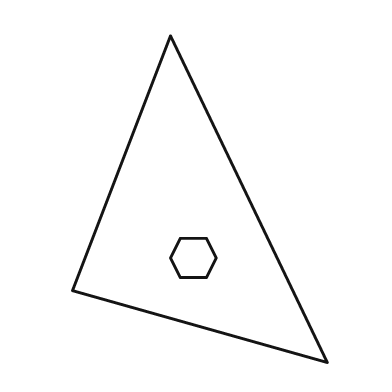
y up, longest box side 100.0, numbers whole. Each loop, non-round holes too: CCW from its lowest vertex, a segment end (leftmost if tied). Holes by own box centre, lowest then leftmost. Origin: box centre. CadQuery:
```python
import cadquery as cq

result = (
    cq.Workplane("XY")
    .moveTo(39.0, -50.0)
    .lineTo(-9.0, 50.0)
    .lineTo(-39.0, -28.0)
    .close()
    .moveTo(-6.0, -24.0)
    .lineTo(2.0, -24.0)
    .lineTo(5.0, -18.0)
    .lineTo(2.0, -12.0)
    .lineTo(-6.0, -12.0)
    .lineTo(-9.0, -18.0)
    .close()
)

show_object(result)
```